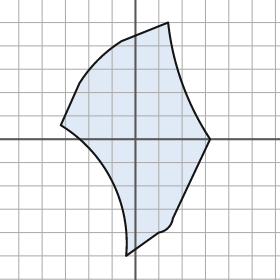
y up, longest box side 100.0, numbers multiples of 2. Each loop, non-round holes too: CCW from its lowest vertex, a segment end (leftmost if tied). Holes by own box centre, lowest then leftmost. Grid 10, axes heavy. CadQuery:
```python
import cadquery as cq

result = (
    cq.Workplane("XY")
    .moveTo(-4.0, -50.0)
    .lineTo(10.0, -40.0)
    .threePointArc((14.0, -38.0), (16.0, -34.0))
    .lineTo(32.0, 0.0)
    .threePointArc((20.0, 24.0), (14.0, 50.0))
    .lineTo(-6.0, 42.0)
    .threePointArc((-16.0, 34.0), (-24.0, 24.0))
    .lineTo(-32.0, 6.0)
    .threePointArc((-10.0, -18.0), (-4.0, -50.0))
    .close()
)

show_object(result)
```